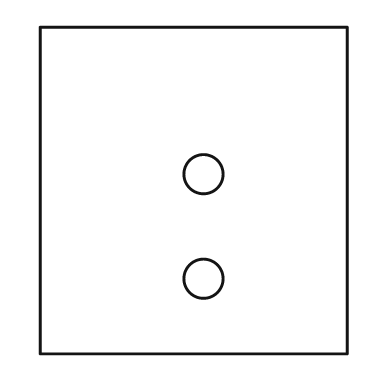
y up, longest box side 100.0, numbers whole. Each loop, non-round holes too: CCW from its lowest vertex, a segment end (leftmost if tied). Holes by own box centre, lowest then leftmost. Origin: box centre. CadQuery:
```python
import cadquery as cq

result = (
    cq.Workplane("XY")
    .moveTo(-47.0, -50.0)
    .lineTo(47.0, -50.0)
    .lineTo(47.0, 50.0)
    .lineTo(-47.0, 50.0)
    .close()
    .moveTo(3.0, -27.0)
    .circle(6.0)
    .moveTo(3.0, 5.0)
    .circle(6.0)
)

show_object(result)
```